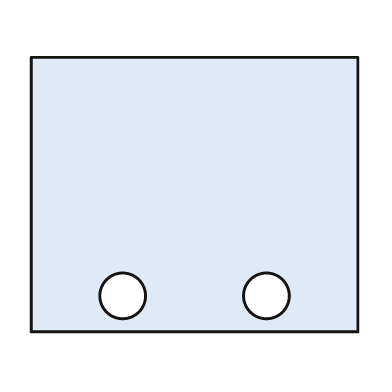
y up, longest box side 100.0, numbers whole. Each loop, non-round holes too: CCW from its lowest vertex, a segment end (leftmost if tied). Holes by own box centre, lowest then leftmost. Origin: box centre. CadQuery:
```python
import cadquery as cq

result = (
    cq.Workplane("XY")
    .moveTo(-50.0, -42.0)
    .lineTo(50.0, -42.0)
    .lineTo(50.0, 42.0)
    .lineTo(-50.0, 42.0)
    .close()
    .moveTo(-22.0, -31.0)
    .circle(7.0)
    .moveTo(22.0, -31.0)
    .circle(7.0)
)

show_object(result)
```